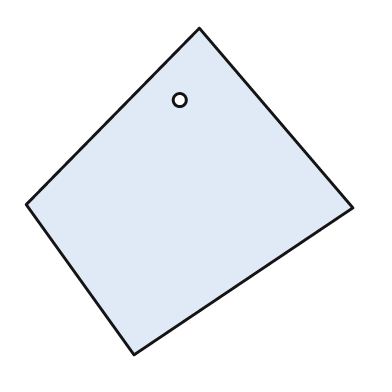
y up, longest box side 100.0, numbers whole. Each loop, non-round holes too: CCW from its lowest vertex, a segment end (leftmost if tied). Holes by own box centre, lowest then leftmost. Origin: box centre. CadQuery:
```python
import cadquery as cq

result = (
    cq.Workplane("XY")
    .moveTo(-17.0, -50.0)
    .lineTo(50.0, -5.0)
    .lineTo(3.0, 50.0)
    .lineTo(-50.0, -4.0)
    .close()
    .moveTo(-3.0, 28.0)
    .circle(2.0)
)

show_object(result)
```